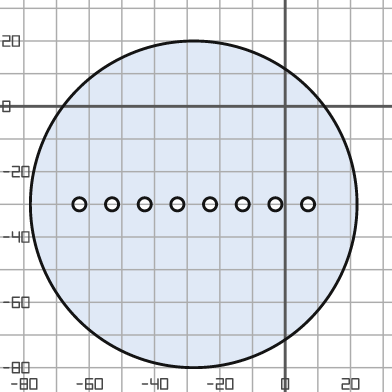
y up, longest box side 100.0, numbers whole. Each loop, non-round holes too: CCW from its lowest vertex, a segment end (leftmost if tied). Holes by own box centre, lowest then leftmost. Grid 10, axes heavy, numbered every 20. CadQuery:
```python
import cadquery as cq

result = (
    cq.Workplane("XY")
    .moveTo(-28.0, -30.0)
    .circle(50.0)
    .moveTo(-63.0, -30.0)
    .circle(2.0)
    .moveTo(-53.0, -30.0)
    .circle(2.0)
    .moveTo(-43.0, -30.0)
    .circle(2.0)
    .moveTo(-33.0, -30.0)
    .circle(2.0)
    .moveTo(-23.0, -30.0)
    .circle(2.0)
    .moveTo(-13.0, -30.0)
    .circle(2.0)
    .moveTo(-3.0, -30.0)
    .circle(2.0)
    .moveTo(7.0, -30.0)
    .circle(2.0)
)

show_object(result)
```